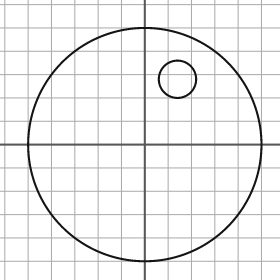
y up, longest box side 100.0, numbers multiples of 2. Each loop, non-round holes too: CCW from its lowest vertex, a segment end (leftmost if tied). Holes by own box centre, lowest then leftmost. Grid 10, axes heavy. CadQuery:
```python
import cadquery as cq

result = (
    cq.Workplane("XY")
    .moveTo(0.0, 0.0)
    .circle(50.0)
    .moveTo(14.0, 28.0)
    .circle(8.0)
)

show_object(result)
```